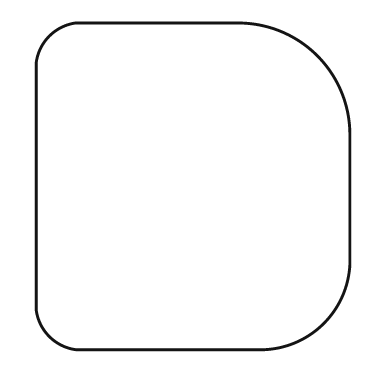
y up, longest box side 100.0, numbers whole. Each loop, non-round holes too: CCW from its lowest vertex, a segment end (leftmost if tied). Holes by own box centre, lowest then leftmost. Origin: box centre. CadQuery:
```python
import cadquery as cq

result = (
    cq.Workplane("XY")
    .moveTo(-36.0, -50.0)
    .lineTo(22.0, -50.0)
    .threePointArc((40.0, -42.0), (48.0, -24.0))
    .lineTo(48.0, 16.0)
    .threePointArc((38.0, 40.0), (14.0, 50.0))
    .lineTo(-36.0, 50.0)
    .threePointArc((-44.0, 46.0), (-48.0, 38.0))
    .lineTo(-48.0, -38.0)
    .threePointArc((-44.0, -46.0), (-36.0, -50.0))
    .close()
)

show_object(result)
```